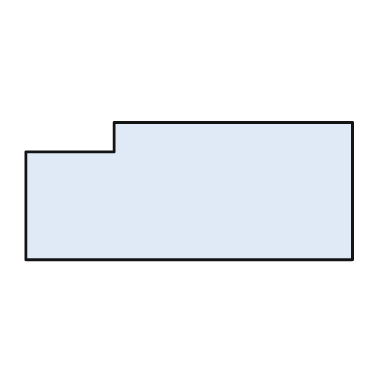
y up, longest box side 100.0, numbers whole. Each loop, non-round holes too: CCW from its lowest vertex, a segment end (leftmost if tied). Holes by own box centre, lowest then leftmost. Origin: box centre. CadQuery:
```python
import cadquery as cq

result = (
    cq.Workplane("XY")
    .moveTo(-50.0, -21.0)
    .lineTo(50.0, -21.0)
    .lineTo(50.0, 21.0)
    .lineTo(-23.0, 21.0)
    .lineTo(-23.0, 12.0)
    .lineTo(-50.0, 12.0)
    .close()
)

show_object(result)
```